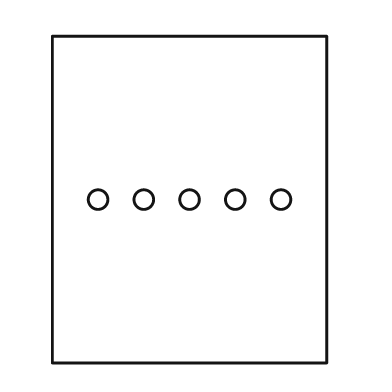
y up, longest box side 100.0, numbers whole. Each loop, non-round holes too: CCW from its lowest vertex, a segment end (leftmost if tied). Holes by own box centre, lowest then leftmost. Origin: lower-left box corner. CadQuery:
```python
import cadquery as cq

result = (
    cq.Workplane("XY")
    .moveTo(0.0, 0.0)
    .lineTo(84.0, 0.0)
    .lineTo(84.0, 100.0)
    .lineTo(0.0, 100.0)
    .close()
    .moveTo(14.0, 50.0)
    .circle(3.0)
    .moveTo(28.0, 50.0)
    .circle(3.0)
    .moveTo(42.0, 50.0)
    .circle(3.0)
    .moveTo(56.0, 50.0)
    .circle(3.0)
    .moveTo(70.0, 50.0)
    .circle(3.0)
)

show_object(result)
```